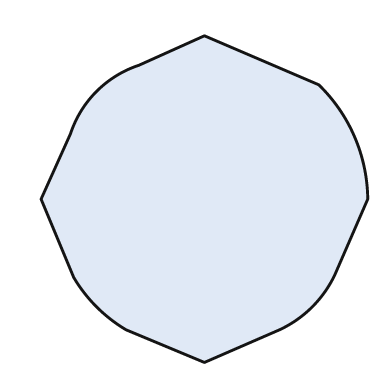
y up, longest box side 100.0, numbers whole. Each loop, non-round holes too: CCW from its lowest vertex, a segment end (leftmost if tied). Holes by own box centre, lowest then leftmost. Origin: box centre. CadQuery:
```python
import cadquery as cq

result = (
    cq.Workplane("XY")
    .moveTo(0.0, -50.0)
    .lineTo(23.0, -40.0)
    .threePointArc((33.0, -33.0), (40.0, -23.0))
    .lineTo(50.0, 0.0)
    .threePointArc((46.0, 19.0), (35.0, 35.0))
    .lineTo(0.0, 50.0)
    .lineTo(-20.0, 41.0)
    .threePointArc((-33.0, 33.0), (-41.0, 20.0))
    .lineTo(-50.0, 0.0)
    .lineTo(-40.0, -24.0)
    .threePointArc((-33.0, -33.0), (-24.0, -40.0))
    .close()
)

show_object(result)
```